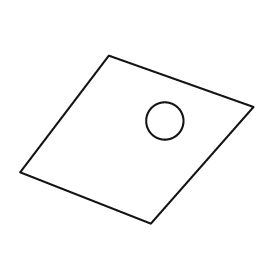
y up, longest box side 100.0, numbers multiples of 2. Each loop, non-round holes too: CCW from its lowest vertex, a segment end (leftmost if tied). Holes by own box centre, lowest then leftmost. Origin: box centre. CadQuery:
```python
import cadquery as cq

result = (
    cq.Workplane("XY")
    .moveTo(6.0, -36.0)
    .lineTo(50.0, 14.0)
    .lineTo(-12.0, 36.0)
    .lineTo(-50.0, -14.0)
    .close()
    .moveTo(12.0, 8.0)
    .circle(8.0)
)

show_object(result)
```